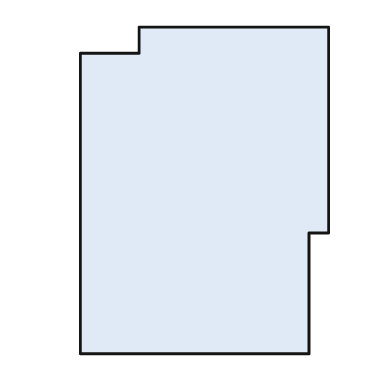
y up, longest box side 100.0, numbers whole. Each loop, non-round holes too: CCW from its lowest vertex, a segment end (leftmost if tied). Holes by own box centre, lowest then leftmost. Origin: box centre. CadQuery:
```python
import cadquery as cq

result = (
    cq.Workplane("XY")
    .moveTo(-38.0, -50.0)
    .lineTo(32.0, -50.0)
    .lineTo(32.0, -13.0)
    .lineTo(38.0, -13.0)
    .lineTo(38.0, 50.0)
    .lineTo(-20.0, 50.0)
    .lineTo(-20.0, 42.0)
    .lineTo(-38.0, 42.0)
    .close()
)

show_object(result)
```